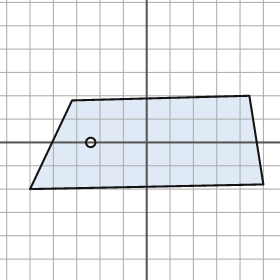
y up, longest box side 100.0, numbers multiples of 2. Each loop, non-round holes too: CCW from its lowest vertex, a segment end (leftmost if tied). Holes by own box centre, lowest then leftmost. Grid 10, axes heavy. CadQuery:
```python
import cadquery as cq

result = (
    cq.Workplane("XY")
    .moveTo(-50.0, -20.0)
    .lineTo(50.0, -18.0)
    .lineTo(44.0, 20.0)
    .lineTo(-32.0, 18.0)
    .close()
    .moveTo(-24.0, 0.0)
    .circle(2.0)
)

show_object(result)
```